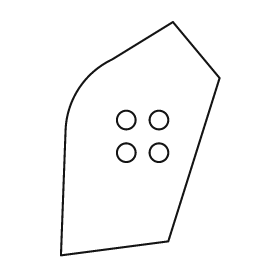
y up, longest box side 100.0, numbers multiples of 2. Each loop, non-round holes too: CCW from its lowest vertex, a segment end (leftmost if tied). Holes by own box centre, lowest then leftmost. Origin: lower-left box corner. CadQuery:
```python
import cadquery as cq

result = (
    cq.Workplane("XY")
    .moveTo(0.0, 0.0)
    .lineTo(46.0, 6.0)
    .lineTo(68.0, 76.0)
    .lineTo(48.0, 100.0)
    .lineTo(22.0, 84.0)
    .threePointArc((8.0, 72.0), (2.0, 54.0))
    .close()
    .moveTo(28.0, 44.0)
    .circle(4.0)
    .moveTo(42.0, 44.0)
    .circle(4.0)
    .moveTo(28.0, 58.0)
    .circle(4.0)
    .moveTo(42.0, 58.0)
    .circle(4.0)
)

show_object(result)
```